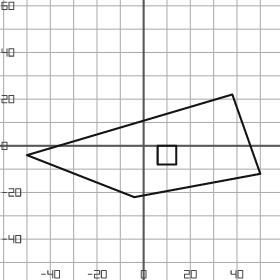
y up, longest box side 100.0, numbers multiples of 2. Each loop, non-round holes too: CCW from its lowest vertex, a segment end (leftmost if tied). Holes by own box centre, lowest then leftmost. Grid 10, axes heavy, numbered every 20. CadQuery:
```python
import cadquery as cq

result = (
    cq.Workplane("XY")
    .moveTo(-4.0, -22.0)
    .lineTo(50.0, -12.0)
    .lineTo(38.0, 22.0)
    .lineTo(-50.0, -4.0)
    .close()
    .moveTo(6.0, -8.0)
    .lineTo(14.0, -8.0)
    .lineTo(14.0, 0.0)
    .lineTo(6.0, 0.0)
    .close()
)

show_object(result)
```